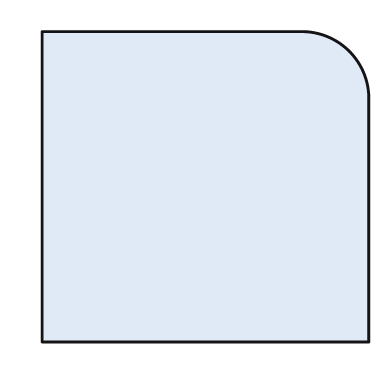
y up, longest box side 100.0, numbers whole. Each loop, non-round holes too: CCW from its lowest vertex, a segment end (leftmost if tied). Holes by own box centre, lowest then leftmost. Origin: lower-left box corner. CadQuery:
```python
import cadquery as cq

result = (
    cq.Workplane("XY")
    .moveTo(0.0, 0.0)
    .lineTo(100.0, 0.0)
    .lineTo(100.0, 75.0)
    .threePointArc((94.0, 89.0), (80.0, 95.0))
    .lineTo(0.0, 95.0)
    .close()
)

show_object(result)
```